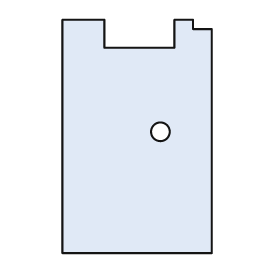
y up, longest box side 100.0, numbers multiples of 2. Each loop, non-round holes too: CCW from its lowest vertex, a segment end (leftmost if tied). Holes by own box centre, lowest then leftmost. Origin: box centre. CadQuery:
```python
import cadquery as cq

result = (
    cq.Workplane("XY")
    .moveTo(-32.0, -50.0)
    .lineTo(32.0, -50.0)
    .lineTo(32.0, 46.0)
    .lineTo(24.0, 46.0)
    .lineTo(24.0, 50.0)
    .lineTo(16.0, 50.0)
    .lineTo(16.0, 38.0)
    .lineTo(-14.0, 38.0)
    .lineTo(-14.0, 50.0)
    .lineTo(-32.0, 50.0)
    .close()
    .moveTo(10.0, 2.0)
    .circle(4.0)
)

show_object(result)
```